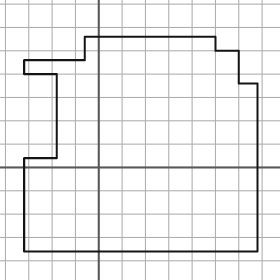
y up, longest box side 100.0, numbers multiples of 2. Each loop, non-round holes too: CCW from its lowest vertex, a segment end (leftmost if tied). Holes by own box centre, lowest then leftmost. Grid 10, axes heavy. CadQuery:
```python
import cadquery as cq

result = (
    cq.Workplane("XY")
    .moveTo(-32.0, -36.0)
    .lineTo(68.0, -36.0)
    .lineTo(68.0, 36.0)
    .lineTo(60.0, 36.0)
    .lineTo(60.0, 50.0)
    .lineTo(50.0, 50.0)
    .lineTo(50.0, 56.0)
    .lineTo(-6.0, 56.0)
    .lineTo(-6.0, 46.0)
    .lineTo(-32.0, 46.0)
    .lineTo(-32.0, 40.0)
    .lineTo(-18.0, 40.0)
    .lineTo(-18.0, 4.0)
    .lineTo(-32.0, 4.0)
    .close()
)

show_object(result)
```